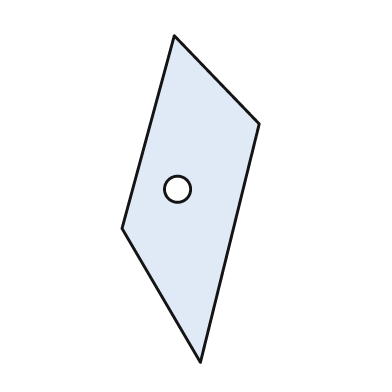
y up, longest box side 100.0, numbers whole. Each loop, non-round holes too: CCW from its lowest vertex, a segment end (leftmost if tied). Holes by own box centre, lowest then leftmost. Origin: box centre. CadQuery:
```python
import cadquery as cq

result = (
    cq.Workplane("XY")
    .moveTo(3.0, -50.0)
    .lineTo(21.0, 23.0)
    .lineTo(-5.0, 50.0)
    .lineTo(-21.0, -9.0)
    .close()
    .moveTo(-4.0, 3.0)
    .circle(4.0)
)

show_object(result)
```